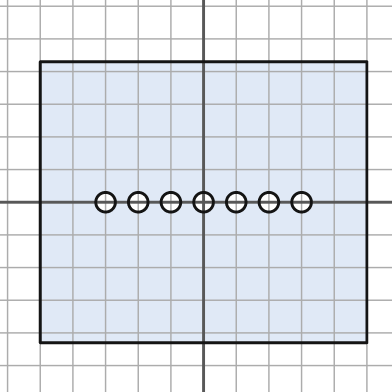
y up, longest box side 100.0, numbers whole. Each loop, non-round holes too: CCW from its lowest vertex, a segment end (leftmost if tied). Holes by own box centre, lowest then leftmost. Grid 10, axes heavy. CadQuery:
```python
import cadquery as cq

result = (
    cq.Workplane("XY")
    .moveTo(-50.0, -43.0)
    .lineTo(50.0, -43.0)
    .lineTo(50.0, 43.0)
    .lineTo(-50.0, 43.0)
    .close()
    .moveTo(-30.0, 0.0)
    .circle(3.0)
    .moveTo(-20.0, 0.0)
    .circle(3.0)
    .moveTo(-10.0, 0.0)
    .circle(3.0)
    .moveTo(0.0, 0.0)
    .circle(3.0)
    .moveTo(10.0, 0.0)
    .circle(3.0)
    .moveTo(20.0, 0.0)
    .circle(3.0)
    .moveTo(30.0, 0.0)
    .circle(3.0)
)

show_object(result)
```